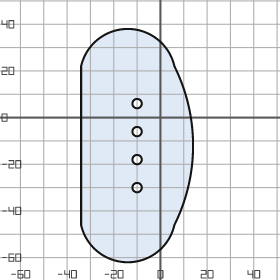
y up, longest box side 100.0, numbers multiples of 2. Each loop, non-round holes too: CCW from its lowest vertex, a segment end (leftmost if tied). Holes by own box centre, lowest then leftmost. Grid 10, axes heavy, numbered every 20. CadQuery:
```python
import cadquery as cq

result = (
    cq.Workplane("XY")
    .moveTo(-34.0, -46.0)
    .threePointArc((-14.0, -62.0), (6.0, -46.0))
    .threePointArc((14.0, -12.0), (6.0, 22.0))
    .threePointArc((-14.0, 38.0), (-34.0, 22.0))
    .close()
    .moveTo(-10.0, -30.0)
    .circle(2.0)
    .moveTo(-10.0, -18.0)
    .circle(2.0)
    .moveTo(-10.0, -6.0)
    .circle(2.0)
    .moveTo(-10.0, 6.0)
    .circle(2.0)
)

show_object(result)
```